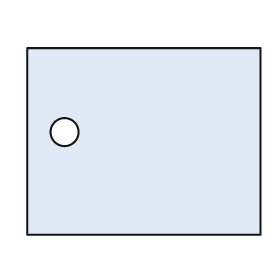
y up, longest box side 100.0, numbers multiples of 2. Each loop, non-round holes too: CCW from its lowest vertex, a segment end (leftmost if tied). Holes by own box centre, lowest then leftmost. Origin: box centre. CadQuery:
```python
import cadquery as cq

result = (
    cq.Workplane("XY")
    .moveTo(-50.0, -40.0)
    .lineTo(50.0, -40.0)
    .lineTo(50.0, 40.0)
    .lineTo(-50.0, 40.0)
    .close()
    .moveTo(-34.0, 4.0)
    .circle(6.0)
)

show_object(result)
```